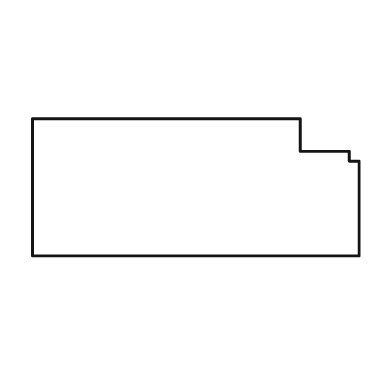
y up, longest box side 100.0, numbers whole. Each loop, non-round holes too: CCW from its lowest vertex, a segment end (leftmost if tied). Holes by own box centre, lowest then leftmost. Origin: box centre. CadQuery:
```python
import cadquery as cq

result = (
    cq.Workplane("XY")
    .moveTo(-50.0, -21.0)
    .lineTo(50.0, -21.0)
    .lineTo(50.0, 8.0)
    .lineTo(47.0, 8.0)
    .lineTo(47.0, 11.0)
    .lineTo(32.0, 11.0)
    .lineTo(32.0, 21.0)
    .lineTo(-50.0, 21.0)
    .close()
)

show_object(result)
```